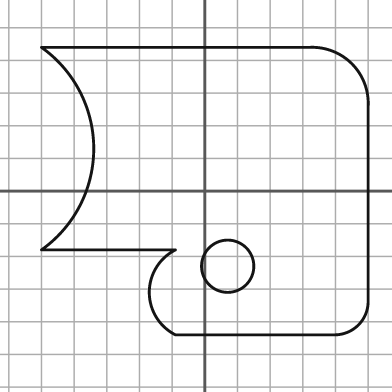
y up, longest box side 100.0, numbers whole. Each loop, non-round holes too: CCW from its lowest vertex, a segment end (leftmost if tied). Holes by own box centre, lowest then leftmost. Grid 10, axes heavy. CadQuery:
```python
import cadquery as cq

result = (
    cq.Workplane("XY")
    .moveTo(-9.0, -44.0)
    .lineTo(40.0, -44.0)
    .threePointArc((47.0, -41.0), (50.0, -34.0))
    .lineTo(50.0, 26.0)
    .threePointArc((45.0, 39.0), (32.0, 44.0))
    .lineTo(-50.0, 44.0)
    .threePointArc((-34.0, 13.0), (-50.0, -18.0))
    .lineTo(-9.0, -18.0)
    .threePointArc((-17.0, -31.0), (-9.0, -44.0))
    .close()
    .moveTo(7.0, -23.0)
    .circle(8.0)
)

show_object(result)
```